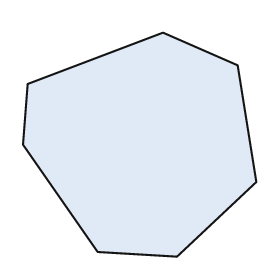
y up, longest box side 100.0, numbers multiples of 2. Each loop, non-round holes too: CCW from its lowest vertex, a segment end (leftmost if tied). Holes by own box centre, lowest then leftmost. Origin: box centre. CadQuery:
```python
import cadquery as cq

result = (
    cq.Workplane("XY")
    .moveTo(16.0, -48.0)
    .lineTo(50.0, -16.0)
    .lineTo(42.0, 34.0)
    .lineTo(10.0, 48.0)
    .lineTo(-48.0, 26.0)
    .lineTo(-50.0, 0.0)
    .lineTo(-18.0, -46.0)
    .close()
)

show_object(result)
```